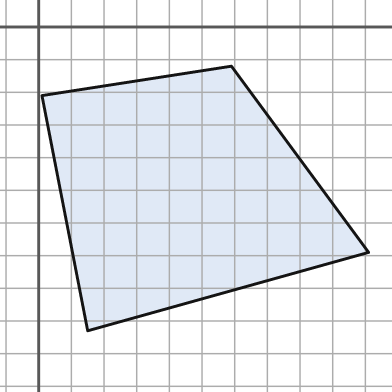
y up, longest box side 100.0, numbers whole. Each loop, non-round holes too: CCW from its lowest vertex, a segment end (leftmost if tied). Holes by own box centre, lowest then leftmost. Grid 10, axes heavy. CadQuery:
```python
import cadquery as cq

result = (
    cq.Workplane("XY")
    .moveTo(15.0, -93.0)
    .lineTo(101.0, -69.0)
    .lineTo(59.0, -12.0)
    .lineTo(1.0, -21.0)
    .close()
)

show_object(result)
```